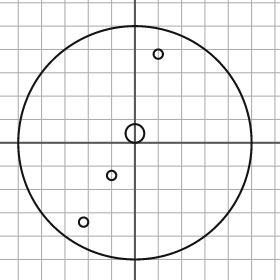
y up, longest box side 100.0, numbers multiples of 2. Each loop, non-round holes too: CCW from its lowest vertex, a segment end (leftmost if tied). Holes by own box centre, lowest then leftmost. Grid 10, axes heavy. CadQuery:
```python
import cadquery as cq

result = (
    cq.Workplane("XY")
    .moveTo(0.0, 0.0)
    .circle(50.0)
    .moveTo(-22.0, -34.0)
    .circle(2.0)
    .moveTo(-10.0, -14.0)
    .circle(2.0)
    .moveTo(0.0, 4.0)
    .circle(4.0)
    .moveTo(10.0, 38.0)
    .circle(2.0)
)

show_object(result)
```